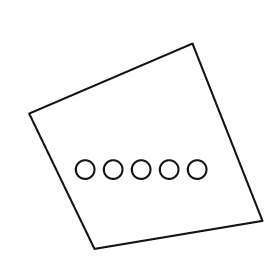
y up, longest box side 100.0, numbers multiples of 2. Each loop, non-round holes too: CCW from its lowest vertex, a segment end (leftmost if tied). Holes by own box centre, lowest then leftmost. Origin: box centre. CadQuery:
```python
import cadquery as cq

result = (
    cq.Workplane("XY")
    .moveTo(-22.0, -44.0)
    .lineTo(50.0, -32.0)
    .lineTo(20.0, 44.0)
    .lineTo(-50.0, 14.0)
    .close()
    .moveTo(-26.0, -10.0)
    .circle(4.0)
    .moveTo(-14.0, -10.0)
    .circle(4.0)
    .moveTo(-2.0, -10.0)
    .circle(4.0)
    .moveTo(10.0, -10.0)
    .circle(4.0)
    .moveTo(22.0, -10.0)
    .circle(4.0)
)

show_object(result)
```